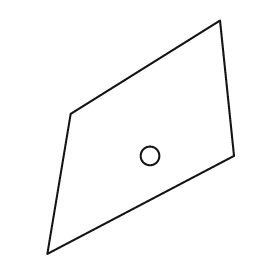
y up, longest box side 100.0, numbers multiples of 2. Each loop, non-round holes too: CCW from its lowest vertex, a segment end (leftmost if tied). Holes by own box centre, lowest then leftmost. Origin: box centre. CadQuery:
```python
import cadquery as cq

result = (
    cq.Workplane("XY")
    .moveTo(-40.0, -50.0)
    .lineTo(40.0, -8.0)
    .lineTo(34.0, 50.0)
    .lineTo(-30.0, 10.0)
    .close()
    .moveTo(4.0, -8.0)
    .circle(4.0)
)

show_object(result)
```